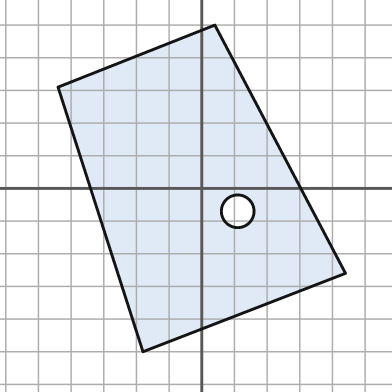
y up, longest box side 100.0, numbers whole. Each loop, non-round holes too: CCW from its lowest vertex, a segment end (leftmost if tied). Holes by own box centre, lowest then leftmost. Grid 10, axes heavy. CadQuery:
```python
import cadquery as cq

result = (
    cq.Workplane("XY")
    .moveTo(-18.0, -50.0)
    .lineTo(44.0, -26.0)
    .lineTo(4.0, 50.0)
    .lineTo(-44.0, 31.0)
    .close()
    .moveTo(11.0, -7.0)
    .circle(5.0)
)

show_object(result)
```